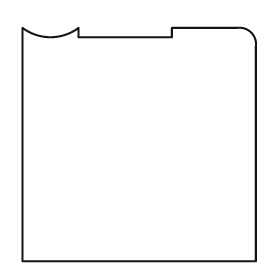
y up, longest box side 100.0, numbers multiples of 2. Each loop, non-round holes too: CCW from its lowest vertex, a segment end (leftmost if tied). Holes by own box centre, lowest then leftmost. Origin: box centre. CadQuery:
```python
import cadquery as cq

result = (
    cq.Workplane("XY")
    .moveTo(-50.0, -50.0)
    .lineTo(50.0, -50.0)
    .lineTo(50.0, 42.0)
    .threePointArc((48.0, 48.0), (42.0, 50.0))
    .lineTo(14.0, 50.0)
    .lineTo(14.0, 46.0)
    .lineTo(-26.0, 46.0)
    .lineTo(-26.0, 50.0)
    .threePointArc((-38.0, 46.0), (-50.0, 50.0))
    .close()
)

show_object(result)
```